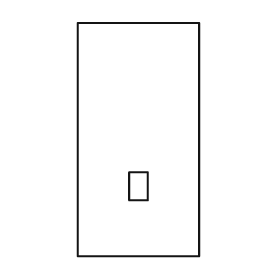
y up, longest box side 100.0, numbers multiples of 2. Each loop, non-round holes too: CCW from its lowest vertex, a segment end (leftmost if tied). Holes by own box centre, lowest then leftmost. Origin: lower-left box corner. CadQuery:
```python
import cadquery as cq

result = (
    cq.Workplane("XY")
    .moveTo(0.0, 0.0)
    .lineTo(52.0, 0.0)
    .lineTo(52.0, 100.0)
    .lineTo(0.0, 100.0)
    .close()
    .moveTo(22.0, 24.0)
    .lineTo(30.0, 24.0)
    .lineTo(30.0, 36.0)
    .lineTo(22.0, 36.0)
    .close()
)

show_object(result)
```